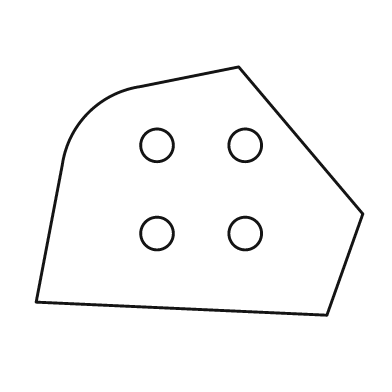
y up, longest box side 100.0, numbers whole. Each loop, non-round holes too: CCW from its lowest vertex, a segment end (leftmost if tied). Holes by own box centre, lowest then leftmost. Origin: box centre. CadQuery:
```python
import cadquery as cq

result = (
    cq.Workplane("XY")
    .moveTo(39.0, -38.0)
    .lineTo(50.0, -7.0)
    .lineTo(12.0, 38.0)
    .lineTo(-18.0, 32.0)
    .threePointArc((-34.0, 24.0), (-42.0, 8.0))
    .lineTo(-50.0, -34.0)
    .close()
    .moveTo(-13.0, -13.0)
    .circle(5.0)
    .moveTo(14.0, -13.0)
    .circle(5.0)
    .moveTo(-13.0, 14.0)
    .circle(5.0)
    .moveTo(14.0, 14.0)
    .circle(5.0)
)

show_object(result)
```